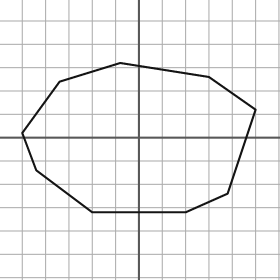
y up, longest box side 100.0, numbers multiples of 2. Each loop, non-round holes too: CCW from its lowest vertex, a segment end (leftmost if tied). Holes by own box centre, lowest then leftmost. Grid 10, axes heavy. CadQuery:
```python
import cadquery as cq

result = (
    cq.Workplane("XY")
    .moveTo(-20.0, -32.0)
    .lineTo(20.0, -32.0)
    .lineTo(38.0, -24.0)
    .lineTo(50.0, 12.0)
    .lineTo(30.0, 26.0)
    .lineTo(-8.0, 32.0)
    .lineTo(-34.0, 24.0)
    .lineTo(-50.0, 2.0)
    .lineTo(-44.0, -14.0)
    .close()
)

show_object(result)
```